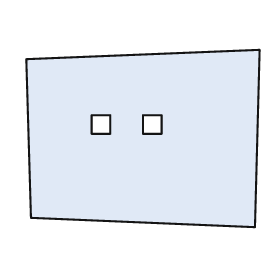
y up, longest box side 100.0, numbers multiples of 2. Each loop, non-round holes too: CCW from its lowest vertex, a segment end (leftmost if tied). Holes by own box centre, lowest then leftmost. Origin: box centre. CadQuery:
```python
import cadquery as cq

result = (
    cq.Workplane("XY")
    .moveTo(48.0, -38.0)
    .lineTo(50.0, 38.0)
    .lineTo(-50.0, 34.0)
    .lineTo(-48.0, -34.0)
    .close()
    .moveTo(-22.0, 2.0)
    .lineTo(-14.0, 2.0)
    .lineTo(-14.0, 10.0)
    .lineTo(-22.0, 10.0)
    .close()
    .moveTo(0.0, 2.0)
    .lineTo(8.0, 2.0)
    .lineTo(8.0, 10.0)
    .lineTo(0.0, 10.0)
    .close()
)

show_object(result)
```